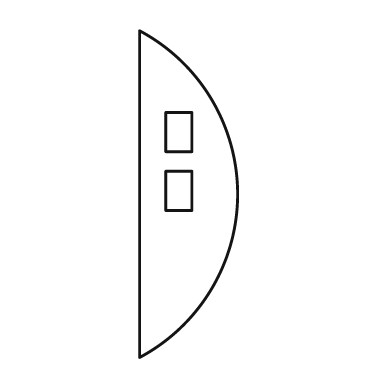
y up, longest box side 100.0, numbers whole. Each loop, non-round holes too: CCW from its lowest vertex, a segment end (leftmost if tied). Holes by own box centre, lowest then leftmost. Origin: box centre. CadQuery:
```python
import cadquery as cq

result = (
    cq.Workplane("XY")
    .moveTo(-15.0, -50.0)
    .threePointArc((15.0, 0.0), (-15.0, 50.0))
    .close()
    .moveTo(-7.0, -5.0)
    .lineTo(1.0, -5.0)
    .lineTo(1.0, 7.0)
    .lineTo(-7.0, 7.0)
    .close()
    .moveTo(-7.0, 13.0)
    .lineTo(1.0, 13.0)
    .lineTo(1.0, 25.0)
    .lineTo(-7.0, 25.0)
    .close()
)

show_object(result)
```